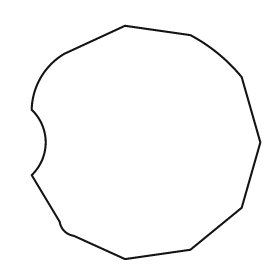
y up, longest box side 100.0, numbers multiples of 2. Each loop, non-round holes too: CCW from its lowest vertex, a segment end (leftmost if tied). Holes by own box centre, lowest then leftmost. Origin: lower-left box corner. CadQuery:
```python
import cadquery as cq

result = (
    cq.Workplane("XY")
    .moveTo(40.0, 0.0)
    .lineTo(68.0, 4.0)
    .lineTo(90.0, 22.0)
    .lineTo(98.0, 50.0)
    .lineTo(90.0, 78.0)
    .threePointArc((80.0, 88.0), (68.0, 96.0))
    .lineTo(40.0, 100.0)
    .lineTo(14.0, 88.0)
    .threePointArc((4.0, 78.0), (0.0, 64.0))
    .threePointArc((6.0, 50.0), (0.0, 36.0))
    .lineTo(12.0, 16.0)
    .threePointArc((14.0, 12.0), (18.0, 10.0))
    .close()
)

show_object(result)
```